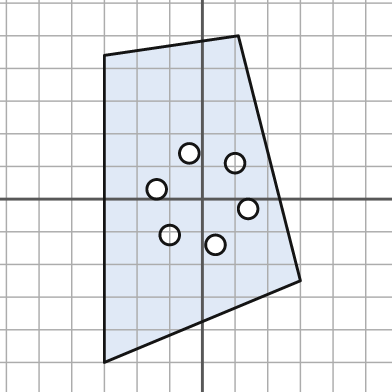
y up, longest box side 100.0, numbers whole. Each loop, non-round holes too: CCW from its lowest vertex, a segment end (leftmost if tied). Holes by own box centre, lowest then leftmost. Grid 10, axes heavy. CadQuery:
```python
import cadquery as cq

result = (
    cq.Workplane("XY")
    .moveTo(-30.0, -50.0)
    .lineTo(30.0, -25.0)
    .lineTo(11.0, 50.0)
    .lineTo(-30.0, 44.0)
    .close()
    .moveTo(4.0, -14.0)
    .circle(3.0)
    .moveTo(-10.0, -11.0)
    .circle(3.0)
    .moveTo(14.0, -3.0)
    .circle(3.0)
    .moveTo(-14.0, 3.0)
    .circle(3.0)
    .moveTo(10.0, 11.0)
    .circle(3.0)
    .moveTo(-4.0, 14.0)
    .circle(3.0)
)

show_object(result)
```